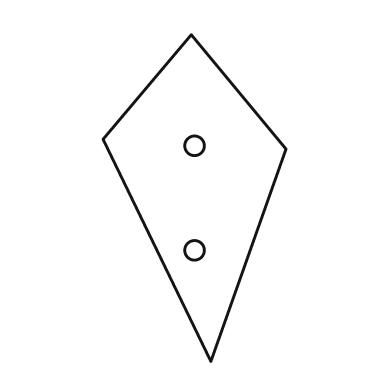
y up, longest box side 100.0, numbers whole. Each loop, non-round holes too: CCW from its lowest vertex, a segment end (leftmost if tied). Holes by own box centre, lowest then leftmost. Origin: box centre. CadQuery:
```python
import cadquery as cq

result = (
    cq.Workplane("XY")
    .moveTo(5.0, -50.0)
    .lineTo(28.0, 15.0)
    .lineTo(-1.0, 50.0)
    .lineTo(-28.0, 18.0)
    .close()
    .moveTo(0.0, -16.0)
    .circle(3.0)
    .moveTo(0.0, 16.0)
    .circle(3.0)
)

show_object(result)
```